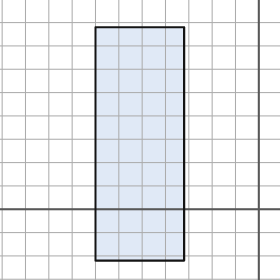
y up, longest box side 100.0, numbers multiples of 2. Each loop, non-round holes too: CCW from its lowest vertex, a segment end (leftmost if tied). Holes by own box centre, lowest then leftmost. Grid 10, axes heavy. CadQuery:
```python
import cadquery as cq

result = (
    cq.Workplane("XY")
    .moveTo(-70.0, -22.0)
    .lineTo(-32.0, -22.0)
    .lineTo(-32.0, 78.0)
    .lineTo(-70.0, 78.0)
    .close()
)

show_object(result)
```